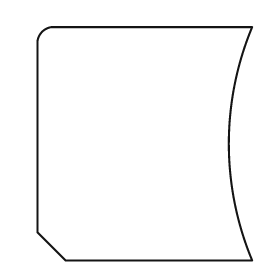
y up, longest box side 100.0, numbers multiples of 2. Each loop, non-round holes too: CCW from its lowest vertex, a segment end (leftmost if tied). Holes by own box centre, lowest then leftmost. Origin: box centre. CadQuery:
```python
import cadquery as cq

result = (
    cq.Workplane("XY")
    .moveTo(-34.0, -50.0)
    .lineTo(46.0, -50.0)
    .threePointArc((36.0, 0.0), (46.0, 50.0))
    .lineTo(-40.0, 50.0)
    .threePointArc((-44.0, 48.0), (-46.0, 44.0))
    .lineTo(-46.0, -38.0)
    .close()
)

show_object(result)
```